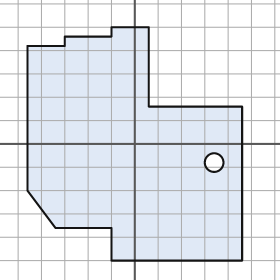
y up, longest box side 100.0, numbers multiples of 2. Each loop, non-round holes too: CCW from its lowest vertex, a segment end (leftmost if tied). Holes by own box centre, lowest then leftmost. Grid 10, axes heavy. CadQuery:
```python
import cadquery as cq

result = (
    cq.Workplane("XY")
    .moveTo(-10.0, -50.0)
    .lineTo(46.0, -50.0)
    .lineTo(46.0, 16.0)
    .lineTo(6.0, 16.0)
    .lineTo(6.0, 50.0)
    .lineTo(-10.0, 50.0)
    .lineTo(-10.0, 46.0)
    .lineTo(-30.0, 46.0)
    .lineTo(-30.0, 42.0)
    .lineTo(-46.0, 42.0)
    .lineTo(-46.0, -20.0)
    .lineTo(-34.0, -36.0)
    .lineTo(-10.0, -36.0)
    .close()
    .moveTo(34.0, -8.0)
    .circle(4.0)
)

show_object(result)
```